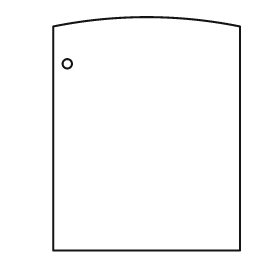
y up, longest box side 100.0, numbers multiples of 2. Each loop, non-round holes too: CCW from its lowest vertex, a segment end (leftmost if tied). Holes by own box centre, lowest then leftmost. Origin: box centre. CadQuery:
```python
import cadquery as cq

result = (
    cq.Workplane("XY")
    .moveTo(-40.0, -50.0)
    .lineTo(40.0, -50.0)
    .lineTo(40.0, 46.0)
    .threePointArc((0.0, 50.0), (-40.0, 46.0))
    .close()
    .moveTo(-34.0, 30.0)
    .circle(2.0)
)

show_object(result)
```